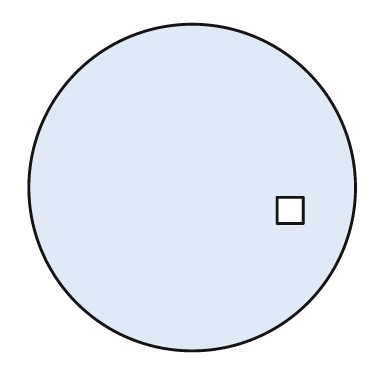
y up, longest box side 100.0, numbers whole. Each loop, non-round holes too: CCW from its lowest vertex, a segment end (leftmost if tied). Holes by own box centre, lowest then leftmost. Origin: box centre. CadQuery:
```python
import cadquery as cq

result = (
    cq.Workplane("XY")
    .moveTo(0.0, 0.0)
    .circle(50.0)
    .moveTo(26.0, -11.0)
    .lineTo(34.0, -11.0)
    .lineTo(34.0, -3.0)
    .lineTo(26.0, -3.0)
    .close()
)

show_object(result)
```